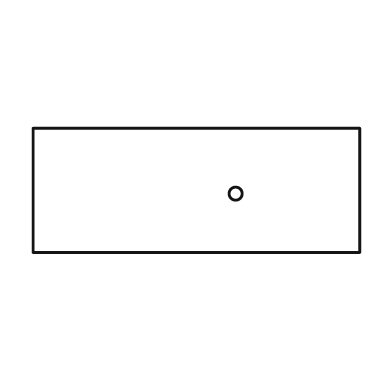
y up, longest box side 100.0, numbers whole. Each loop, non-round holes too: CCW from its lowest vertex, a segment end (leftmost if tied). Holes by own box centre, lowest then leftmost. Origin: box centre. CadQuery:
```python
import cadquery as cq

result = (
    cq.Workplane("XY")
    .moveTo(-50.0, -19.0)
    .lineTo(50.0, -19.0)
    .lineTo(50.0, 19.0)
    .lineTo(-50.0, 19.0)
    .close()
    .moveTo(12.0, -1.0)
    .circle(2.0)
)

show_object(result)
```